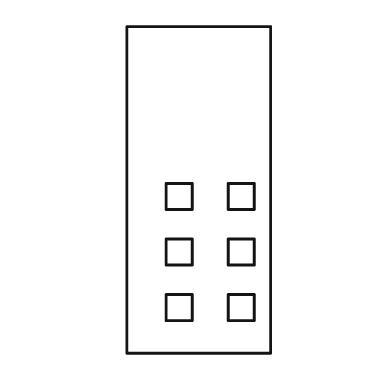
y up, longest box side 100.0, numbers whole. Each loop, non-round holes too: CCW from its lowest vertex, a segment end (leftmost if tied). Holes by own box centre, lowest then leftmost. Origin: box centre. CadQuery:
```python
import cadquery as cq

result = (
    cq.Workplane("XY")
    .moveTo(-22.0, -50.0)
    .lineTo(22.0, -50.0)
    .lineTo(22.0, 50.0)
    .lineTo(-22.0, 50.0)
    .close()
    .moveTo(-10.0, -40.0)
    .lineTo(-2.0, -40.0)
    .lineTo(-2.0, -32.0)
    .lineTo(-10.0, -32.0)
    .close()
    .moveTo(9.0, -40.0)
    .lineTo(17.0, -40.0)
    .lineTo(17.0, -32.0)
    .lineTo(9.0, -32.0)
    .close()
    .moveTo(-10.0, -23.0)
    .lineTo(-2.0, -23.0)
    .lineTo(-2.0, -15.0)
    .lineTo(-10.0, -15.0)
    .close()
    .moveTo(9.0, -23.0)
    .lineTo(17.0, -23.0)
    .lineTo(17.0, -15.0)
    .lineTo(9.0, -15.0)
    .close()
    .moveTo(-10.0, -6.0)
    .lineTo(-2.0, -6.0)
    .lineTo(-2.0, 2.0)
    .lineTo(-10.0, 2.0)
    .close()
    .moveTo(9.0, -6.0)
    .lineTo(17.0, -6.0)
    .lineTo(17.0, 2.0)
    .lineTo(9.0, 2.0)
    .close()
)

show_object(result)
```